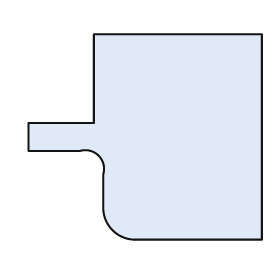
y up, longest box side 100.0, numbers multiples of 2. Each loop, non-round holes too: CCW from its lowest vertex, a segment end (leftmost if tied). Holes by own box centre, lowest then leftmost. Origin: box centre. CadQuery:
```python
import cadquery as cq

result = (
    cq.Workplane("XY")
    .moveTo(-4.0, -44.0)
    .lineTo(50.0, -44.0)
    .lineTo(50.0, 44.0)
    .lineTo(-22.0, 44.0)
    .lineTo(-22.0, 6.0)
    .lineTo(-50.0, 6.0)
    .lineTo(-50.0, -6.0)
    .lineTo(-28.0, -6.0)
    .threePointArc((-20.0, -8.0), (-18.0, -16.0))
    .lineTo(-18.0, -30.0)
    .threePointArc((-14.0, -40.0), (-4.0, -44.0))
    .close()
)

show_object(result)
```